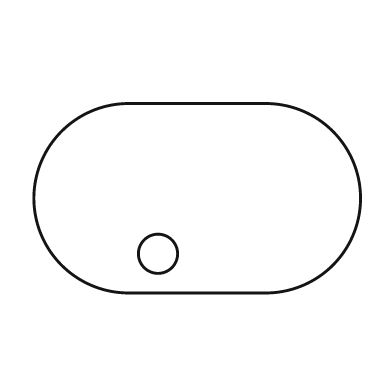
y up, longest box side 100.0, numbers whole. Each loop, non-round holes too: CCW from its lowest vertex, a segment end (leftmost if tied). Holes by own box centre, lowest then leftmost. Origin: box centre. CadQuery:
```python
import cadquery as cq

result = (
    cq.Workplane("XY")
    .moveTo(-21.0, -29.0)
    .lineTo(21.0, -29.0)
    .threePointArc((50.0, 0.0), (21.0, 29.0))
    .lineTo(-21.0, 29.0)
    .threePointArc((-50.0, 0.0), (-21.0, -29.0))
    .close()
    .moveTo(-12.0, -17.0)
    .circle(6.0)
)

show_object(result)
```